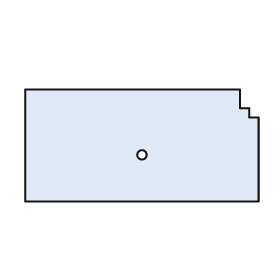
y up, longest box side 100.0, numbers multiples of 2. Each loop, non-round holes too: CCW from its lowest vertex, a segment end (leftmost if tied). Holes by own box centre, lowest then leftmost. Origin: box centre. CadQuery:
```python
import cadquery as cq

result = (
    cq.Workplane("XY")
    .moveTo(-50.0, -24.0)
    .lineTo(50.0, -24.0)
    .lineTo(50.0, 12.0)
    .lineTo(46.0, 12.0)
    .lineTo(46.0, 16.0)
    .lineTo(42.0, 16.0)
    .lineTo(42.0, 24.0)
    .lineTo(-50.0, 24.0)
    .close()
    .moveTo(0.0, -4.0)
    .circle(2.0)
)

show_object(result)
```